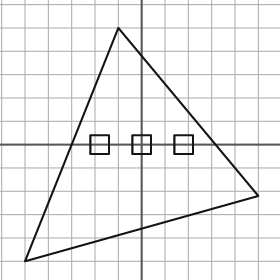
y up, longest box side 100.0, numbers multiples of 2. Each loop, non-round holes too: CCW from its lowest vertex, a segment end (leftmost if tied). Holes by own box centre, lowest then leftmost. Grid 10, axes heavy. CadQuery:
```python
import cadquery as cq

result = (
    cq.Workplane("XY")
    .moveTo(-50.0, -50.0)
    .lineTo(50.0, -22.0)
    .lineTo(-10.0, 50.0)
    .close()
    .moveTo(-22.0, -4.0)
    .lineTo(-14.0, -4.0)
    .lineTo(-14.0, 4.0)
    .lineTo(-22.0, 4.0)
    .close()
    .moveTo(-4.0, -4.0)
    .lineTo(4.0, -4.0)
    .lineTo(4.0, 4.0)
    .lineTo(-4.0, 4.0)
    .close()
    .moveTo(14.0, -4.0)
    .lineTo(22.0, -4.0)
    .lineTo(22.0, 4.0)
    .lineTo(14.0, 4.0)
    .close()
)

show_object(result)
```